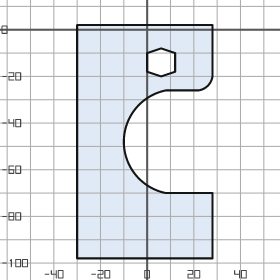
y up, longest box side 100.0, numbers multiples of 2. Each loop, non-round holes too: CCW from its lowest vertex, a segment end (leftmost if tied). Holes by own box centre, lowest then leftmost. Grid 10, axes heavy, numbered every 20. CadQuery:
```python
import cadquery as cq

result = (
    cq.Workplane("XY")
    .moveTo(-30.0, -98.0)
    .lineTo(28.0, -98.0)
    .lineTo(28.0, -70.0)
    .lineTo(8.0, -70.0)
    .threePointArc((-10.0, -48.0), (8.0, -26.0))
    .lineTo(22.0, -26.0)
    .threePointArc((26.0, -24.0), (28.0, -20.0))
    .lineTo(28.0, 2.0)
    .lineTo(-30.0, 2.0)
    .close()
    .moveTo(6.0, -20.0)
    .lineTo(12.0, -18.0)
    .lineTo(12.0, -10.0)
    .lineTo(6.0, -8.0)
    .lineTo(0.0, -10.0)
    .lineTo(0.0, -18.0)
    .close()
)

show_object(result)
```